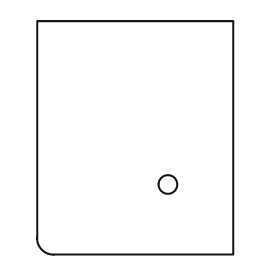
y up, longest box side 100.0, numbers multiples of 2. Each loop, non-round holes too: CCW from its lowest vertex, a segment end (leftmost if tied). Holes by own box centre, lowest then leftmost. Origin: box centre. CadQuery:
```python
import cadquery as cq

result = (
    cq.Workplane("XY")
    .moveTo(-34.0, -50.0)
    .lineTo(42.0, -50.0)
    .lineTo(42.0, 50.0)
    .lineTo(-42.0, 50.0)
    .lineTo(-42.0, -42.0)
    .threePointArc((-40.0, -48.0), (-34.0, -50.0))
    .close()
    .moveTo(14.0, -20.0)
    .circle(4.0)
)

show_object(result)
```